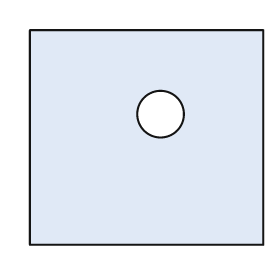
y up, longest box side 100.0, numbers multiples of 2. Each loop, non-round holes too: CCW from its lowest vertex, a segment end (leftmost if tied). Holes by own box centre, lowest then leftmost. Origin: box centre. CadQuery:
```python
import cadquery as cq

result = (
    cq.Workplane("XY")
    .moveTo(-50.0, -46.0)
    .lineTo(50.0, -46.0)
    .lineTo(50.0, 46.0)
    .lineTo(-50.0, 46.0)
    .close()
    .moveTo(6.0, 10.0)
    .circle(10.0)
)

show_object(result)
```